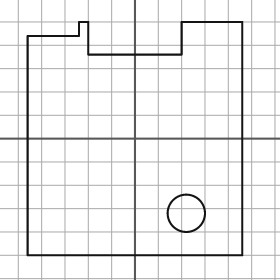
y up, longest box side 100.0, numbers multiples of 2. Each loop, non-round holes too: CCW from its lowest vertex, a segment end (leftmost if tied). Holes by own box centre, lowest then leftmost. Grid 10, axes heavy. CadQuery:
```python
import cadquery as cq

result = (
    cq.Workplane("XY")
    .moveTo(-46.0, -50.0)
    .lineTo(46.0, -50.0)
    .lineTo(46.0, 50.0)
    .lineTo(20.0, 50.0)
    .lineTo(20.0, 36.0)
    .lineTo(-20.0, 36.0)
    .lineTo(-20.0, 50.0)
    .lineTo(-24.0, 50.0)
    .lineTo(-24.0, 44.0)
    .lineTo(-46.0, 44.0)
    .close()
    .moveTo(22.0, -32.0)
    .circle(8.0)
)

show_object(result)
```